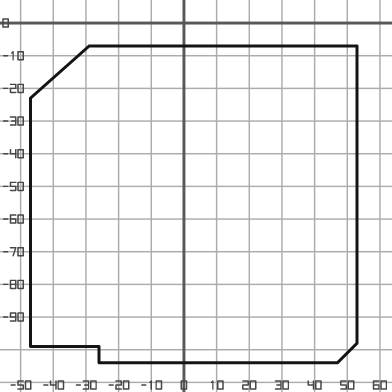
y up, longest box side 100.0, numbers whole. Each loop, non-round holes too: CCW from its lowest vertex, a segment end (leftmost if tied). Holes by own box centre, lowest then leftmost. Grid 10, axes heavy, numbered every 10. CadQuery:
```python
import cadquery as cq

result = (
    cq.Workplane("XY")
    .moveTo(-26.0, -104.0)
    .lineTo(47.0, -104.0)
    .lineTo(53.0, -98.0)
    .lineTo(53.0, -7.0)
    .lineTo(-29.0, -7.0)
    .lineTo(-47.0, -23.0)
    .lineTo(-47.0, -99.0)
    .lineTo(-26.0, -99.0)
    .close()
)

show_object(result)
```